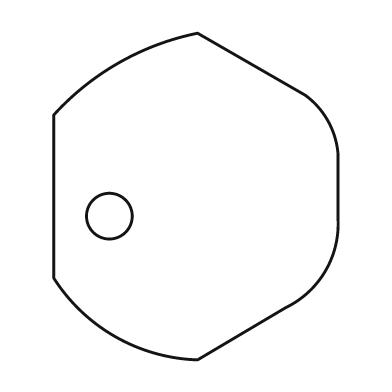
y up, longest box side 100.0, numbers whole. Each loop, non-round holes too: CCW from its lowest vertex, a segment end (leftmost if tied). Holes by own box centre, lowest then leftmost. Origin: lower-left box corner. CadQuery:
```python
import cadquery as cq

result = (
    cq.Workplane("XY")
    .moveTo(44.0, 0.0)
    .lineTo(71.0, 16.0)
    .threePointArc((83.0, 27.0), (87.0, 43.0))
    .lineTo(87.0, 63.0)
    .threePointArc((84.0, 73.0), (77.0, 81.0))
    .lineTo(44.0, 100.0)
    .threePointArc((20.0, 91.0), (0.0, 75.0))
    .lineTo(0.0, 25.0)
    .threePointArc((19.0, 7.0), (44.0, 0.0))
    .close()
    .moveTo(17.0, 44.0)
    .circle(7.0)
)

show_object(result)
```